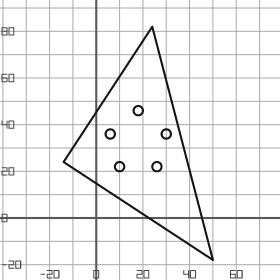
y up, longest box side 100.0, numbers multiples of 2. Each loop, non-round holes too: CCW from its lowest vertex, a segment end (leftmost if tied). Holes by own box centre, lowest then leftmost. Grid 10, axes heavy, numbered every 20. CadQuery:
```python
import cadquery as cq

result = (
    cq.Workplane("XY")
    .moveTo(50.0, -18.0)
    .lineTo(24.0, 82.0)
    .lineTo(-14.0, 24.0)
    .close()
    .moveTo(10.0, 22.0)
    .circle(2.0)
    .moveTo(26.0, 22.0)
    .circle(2.0)
    .moveTo(6.0, 36.0)
    .circle(2.0)
    .moveTo(30.0, 36.0)
    .circle(2.0)
    .moveTo(18.0, 46.0)
    .circle(2.0)
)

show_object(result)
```